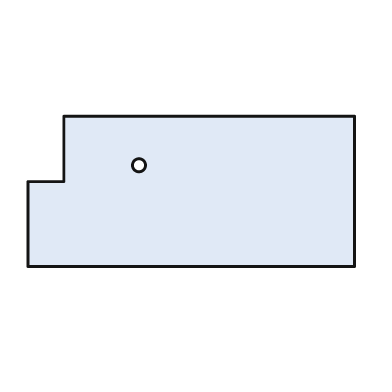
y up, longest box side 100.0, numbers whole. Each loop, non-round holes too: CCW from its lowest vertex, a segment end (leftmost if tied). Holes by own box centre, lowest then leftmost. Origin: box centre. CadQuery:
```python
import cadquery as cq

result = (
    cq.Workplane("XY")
    .moveTo(-50.0, -23.0)
    .lineTo(50.0, -23.0)
    .lineTo(50.0, 23.0)
    .lineTo(-39.0, 23.0)
    .lineTo(-39.0, 3.0)
    .lineTo(-50.0, 3.0)
    .close()
    .moveTo(-16.0, 8.0)
    .circle(2.0)
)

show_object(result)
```